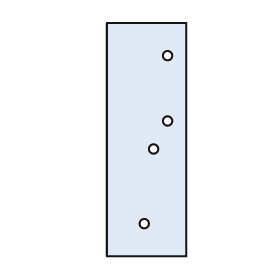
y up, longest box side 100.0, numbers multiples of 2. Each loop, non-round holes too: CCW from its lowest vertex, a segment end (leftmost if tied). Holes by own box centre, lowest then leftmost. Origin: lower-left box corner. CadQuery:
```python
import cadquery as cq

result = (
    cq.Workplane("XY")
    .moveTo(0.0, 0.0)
    .lineTo(34.0, 0.0)
    .lineTo(34.0, 100.0)
    .lineTo(0.0, 100.0)
    .close()
    .moveTo(16.0, 14.0)
    .circle(2.0)
    .moveTo(20.0, 46.0)
    .circle(2.0)
    .moveTo(26.0, 58.0)
    .circle(2.0)
    .moveTo(26.0, 86.0)
    .circle(2.0)
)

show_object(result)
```